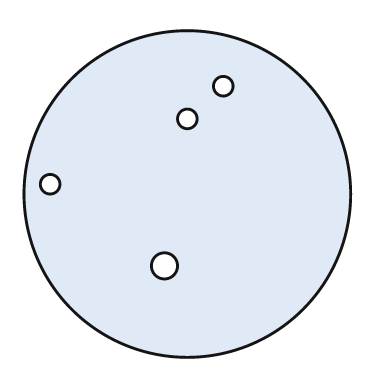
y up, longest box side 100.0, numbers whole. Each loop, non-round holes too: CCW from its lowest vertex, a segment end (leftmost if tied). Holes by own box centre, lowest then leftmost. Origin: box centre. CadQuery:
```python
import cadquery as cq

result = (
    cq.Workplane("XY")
    .moveTo(0.0, 0.0)
    .circle(50.0)
    .moveTo(-7.0, -22.0)
    .circle(4.0)
    .moveTo(-42.0, 3.0)
    .circle(3.0)
    .moveTo(0.0, 23.0)
    .circle(3.0)
    .moveTo(11.0, 33.0)
    .circle(3.0)
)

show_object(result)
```